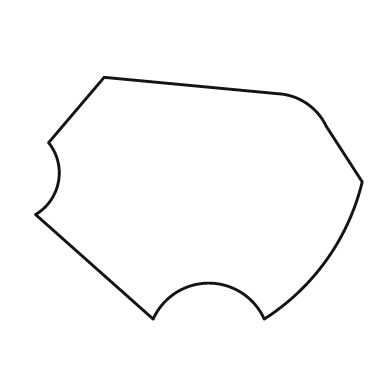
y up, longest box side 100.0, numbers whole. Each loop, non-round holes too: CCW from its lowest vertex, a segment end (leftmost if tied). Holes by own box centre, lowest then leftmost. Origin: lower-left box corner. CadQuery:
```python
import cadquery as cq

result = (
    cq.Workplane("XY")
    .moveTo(36.0, 0.0)
    .threePointArc((53.0, 11.0), (70.0, 0.0))
    .threePointArc((89.0, 18.0), (100.0, 42.0))
    .lineTo(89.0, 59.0)
    .threePointArc((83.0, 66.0), (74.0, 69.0))
    .lineTo(21.0, 74.0)
    .lineTo(4.0, 54.0)
    .threePointArc((7.0, 42.0), (0.0, 32.0))
    .close()
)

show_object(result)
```